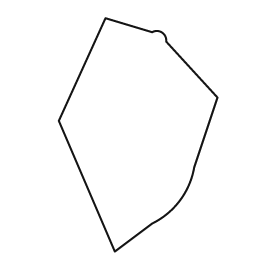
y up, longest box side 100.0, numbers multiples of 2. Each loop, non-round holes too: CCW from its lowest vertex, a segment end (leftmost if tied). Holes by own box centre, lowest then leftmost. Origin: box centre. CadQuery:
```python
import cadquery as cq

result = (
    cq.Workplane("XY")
    .moveTo(-10.0, -50.0)
    .lineTo(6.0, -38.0)
    .threePointArc((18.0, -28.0), (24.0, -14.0))
    .lineTo(34.0, 16.0)
    .lineTo(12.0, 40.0)
    .threePointArc((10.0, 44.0), (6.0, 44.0))
    .lineTo(-14.0, 50.0)
    .lineTo(-34.0, 6.0)
    .close()
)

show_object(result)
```